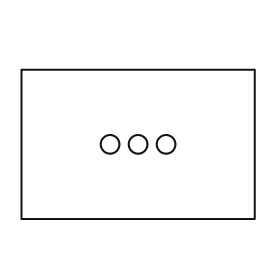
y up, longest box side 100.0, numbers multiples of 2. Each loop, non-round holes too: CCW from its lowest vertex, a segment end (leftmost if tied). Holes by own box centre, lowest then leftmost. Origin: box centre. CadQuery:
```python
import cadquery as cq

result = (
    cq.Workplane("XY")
    .moveTo(-50.0, -32.0)
    .lineTo(50.0, -32.0)
    .lineTo(50.0, 32.0)
    .lineTo(-50.0, 32.0)
    .close()
    .moveTo(-12.0, 0.0)
    .circle(4.0)
    .moveTo(0.0, 0.0)
    .circle(4.0)
    .moveTo(12.0, 0.0)
    .circle(4.0)
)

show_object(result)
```